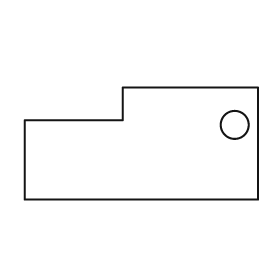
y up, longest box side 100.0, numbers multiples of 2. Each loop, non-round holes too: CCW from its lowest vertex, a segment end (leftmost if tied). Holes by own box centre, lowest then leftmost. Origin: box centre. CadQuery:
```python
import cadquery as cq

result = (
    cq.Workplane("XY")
    .moveTo(-50.0, -24.0)
    .lineTo(50.0, -24.0)
    .lineTo(50.0, 24.0)
    .lineTo(-8.0, 24.0)
    .lineTo(-8.0, 10.0)
    .lineTo(-50.0, 10.0)
    .close()
    .moveTo(40.0, 8.0)
    .circle(6.0)
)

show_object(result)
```